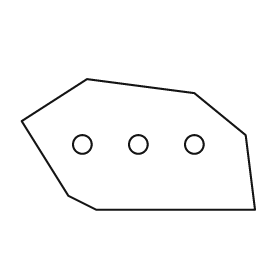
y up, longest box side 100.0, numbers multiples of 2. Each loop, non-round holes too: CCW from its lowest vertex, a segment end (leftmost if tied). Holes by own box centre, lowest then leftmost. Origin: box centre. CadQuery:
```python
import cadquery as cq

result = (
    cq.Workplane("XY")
    .moveTo(-18.0, -28.0)
    .lineTo(50.0, -28.0)
    .lineTo(46.0, 4.0)
    .lineTo(24.0, 22.0)
    .lineTo(-22.0, 28.0)
    .lineTo(-50.0, 10.0)
    .lineTo(-30.0, -22.0)
    .close()
    .moveTo(-24.0, 0.0)
    .circle(4.0)
    .moveTo(0.0, 0.0)
    .circle(4.0)
    .moveTo(24.0, 0.0)
    .circle(4.0)
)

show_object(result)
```